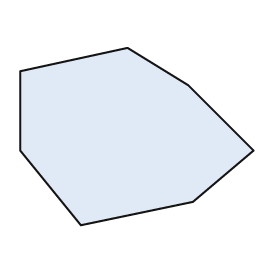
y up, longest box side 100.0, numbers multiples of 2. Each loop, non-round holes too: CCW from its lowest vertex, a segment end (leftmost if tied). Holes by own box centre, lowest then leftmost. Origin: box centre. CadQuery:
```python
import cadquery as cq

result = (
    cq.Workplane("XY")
    .moveTo(-24.0, -38.0)
    .lineTo(24.0, -28.0)
    .lineTo(50.0, -6.0)
    .lineTo(22.0, 22.0)
    .lineTo(-4.0, 38.0)
    .lineTo(-50.0, 28.0)
    .lineTo(-50.0, -6.0)
    .close()
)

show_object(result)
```